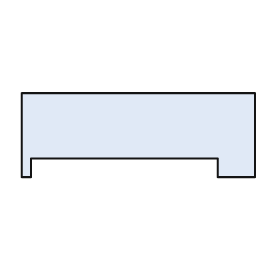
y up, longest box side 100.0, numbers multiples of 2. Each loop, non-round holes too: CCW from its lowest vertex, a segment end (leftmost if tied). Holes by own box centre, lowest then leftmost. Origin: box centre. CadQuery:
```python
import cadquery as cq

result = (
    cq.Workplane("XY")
    .moveTo(-50.0, -18.0)
    .lineTo(-46.0, -18.0)
    .lineTo(-46.0, -10.0)
    .lineTo(34.0, -10.0)
    .lineTo(34.0, -18.0)
    .lineTo(50.0, -18.0)
    .lineTo(50.0, 18.0)
    .lineTo(-50.0, 18.0)
    .close()
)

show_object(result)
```